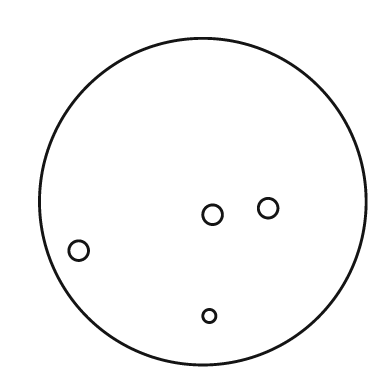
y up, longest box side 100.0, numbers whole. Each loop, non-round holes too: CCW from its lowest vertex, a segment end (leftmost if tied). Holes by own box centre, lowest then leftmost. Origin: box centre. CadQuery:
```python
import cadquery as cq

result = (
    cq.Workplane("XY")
    .moveTo(0.0, 0.0)
    .circle(50.0)
    .moveTo(2.0, -35.0)
    .circle(2.0)
    .moveTo(-38.0, -15.0)
    .circle(3.0)
    .moveTo(3.0, -4.0)
    .circle(3.0)
    .moveTo(20.0, -2.0)
    .circle(3.0)
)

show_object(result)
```